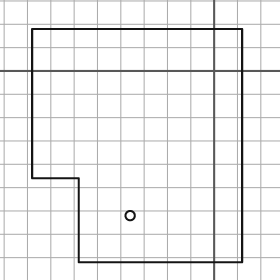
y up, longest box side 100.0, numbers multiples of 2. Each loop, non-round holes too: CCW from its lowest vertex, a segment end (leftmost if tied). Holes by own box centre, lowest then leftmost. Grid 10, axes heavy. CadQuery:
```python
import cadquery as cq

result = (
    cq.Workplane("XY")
    .moveTo(-58.0, -82.0)
    .lineTo(12.0, -82.0)
    .lineTo(12.0, 18.0)
    .lineTo(-78.0, 18.0)
    .lineTo(-78.0, -46.0)
    .lineTo(-58.0, -46.0)
    .close()
    .moveTo(-36.0, -62.0)
    .circle(2.0)
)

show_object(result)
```